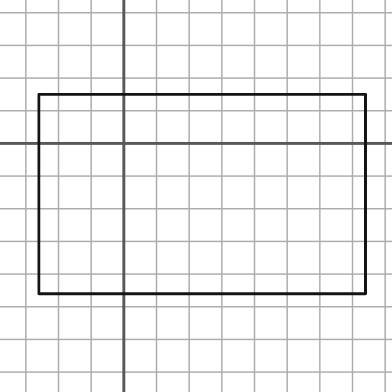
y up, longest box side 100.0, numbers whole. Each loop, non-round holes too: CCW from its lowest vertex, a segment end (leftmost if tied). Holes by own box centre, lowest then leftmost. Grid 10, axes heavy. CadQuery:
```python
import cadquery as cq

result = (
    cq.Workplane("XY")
    .moveTo(-26.0, -46.0)
    .lineTo(74.0, -46.0)
    .lineTo(74.0, 15.0)
    .lineTo(-26.0, 15.0)
    .close()
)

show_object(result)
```